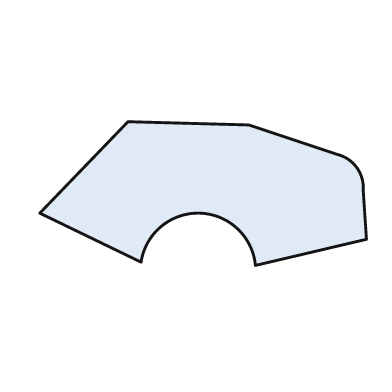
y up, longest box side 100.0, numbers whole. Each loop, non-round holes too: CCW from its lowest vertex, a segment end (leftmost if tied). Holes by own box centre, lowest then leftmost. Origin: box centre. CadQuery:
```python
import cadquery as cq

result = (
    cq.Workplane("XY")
    .moveTo(16.0, -22.0)
    .lineTo(50.0, -14.0)
    .lineTo(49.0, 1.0)
    .threePointArc((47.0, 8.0), (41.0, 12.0))
    .lineTo(14.0, 21.0)
    .lineTo(-23.0, 22.0)
    .lineTo(-50.0, -6.0)
    .lineTo(-19.0, -21.0)
    .threePointArc((-1.0, -6.0), (16.0, -22.0))
    .close()
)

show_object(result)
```